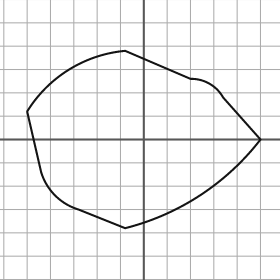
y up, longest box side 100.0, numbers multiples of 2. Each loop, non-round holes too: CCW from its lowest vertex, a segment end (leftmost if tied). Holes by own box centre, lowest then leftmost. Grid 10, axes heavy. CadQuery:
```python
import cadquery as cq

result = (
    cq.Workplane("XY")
    .moveTo(-8.0, -38.0)
    .threePointArc((24.0, -24.0), (50.0, 0.0))
    .lineTo(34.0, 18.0)
    .threePointArc((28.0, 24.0), (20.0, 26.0))
    .lineTo(-8.0, 38.0)
    .threePointArc((-32.0, 30.0), (-50.0, 12.0))
    .lineTo(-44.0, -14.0)
    .threePointArc((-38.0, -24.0), (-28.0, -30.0))
    .close()
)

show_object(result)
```